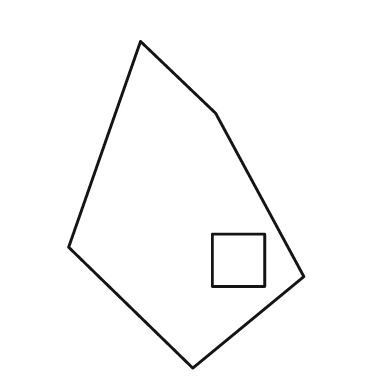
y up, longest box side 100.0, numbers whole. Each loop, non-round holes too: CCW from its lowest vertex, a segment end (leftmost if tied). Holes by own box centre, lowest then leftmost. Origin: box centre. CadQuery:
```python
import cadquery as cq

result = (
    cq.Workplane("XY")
    .moveTo(2.0, -50.0)
    .lineTo(36.0, -22.0)
    .lineTo(9.0, 28.0)
    .lineTo(-14.0, 50.0)
    .lineTo(-36.0, -13.0)
    .close()
    .moveTo(8.0, -25.0)
    .lineTo(24.0, -25.0)
    .lineTo(24.0, -9.0)
    .lineTo(8.0, -9.0)
    .close()
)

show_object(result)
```